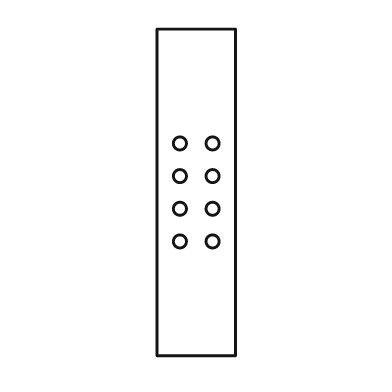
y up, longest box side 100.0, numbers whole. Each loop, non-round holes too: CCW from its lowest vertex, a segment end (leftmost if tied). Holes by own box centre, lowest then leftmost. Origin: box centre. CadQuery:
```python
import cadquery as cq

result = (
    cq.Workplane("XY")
    .moveTo(-12.0, -50.0)
    .lineTo(12.0, -50.0)
    .lineTo(12.0, 50.0)
    .lineTo(-12.0, 50.0)
    .close()
    .moveTo(-5.0, -15.0)
    .circle(2.0)
    .moveTo(5.0, -15.0)
    .circle(2.0)
    .moveTo(-5.0, -5.0)
    .circle(2.0)
    .moveTo(5.0, -5.0)
    .circle(2.0)
    .moveTo(-5.0, 5.0)
    .circle(2.0)
    .moveTo(5.0, 5.0)
    .circle(2.0)
    .moveTo(-5.0, 15.0)
    .circle(2.0)
    .moveTo(5.0, 15.0)
    .circle(2.0)
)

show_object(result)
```